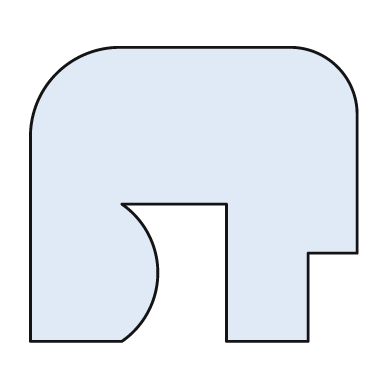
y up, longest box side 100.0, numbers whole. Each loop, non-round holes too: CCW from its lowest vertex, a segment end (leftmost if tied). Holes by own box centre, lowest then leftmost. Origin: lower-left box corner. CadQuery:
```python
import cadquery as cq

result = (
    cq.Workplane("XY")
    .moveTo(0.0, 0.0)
    .lineTo(28.0, 0.0)
    .threePointArc((39.0, 21.0), (28.0, 42.0))
    .lineTo(60.0, 42.0)
    .lineTo(60.0, 0.0)
    .lineTo(85.0, 0.0)
    .lineTo(85.0, 27.0)
    .lineTo(100.0, 27.0)
    .lineTo(100.0, 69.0)
    .threePointArc((94.0, 84.0), (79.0, 90.0))
    .lineTo(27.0, 90.0)
    .threePointArc((8.0, 82.0), (0.0, 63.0))
    .close()
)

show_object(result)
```